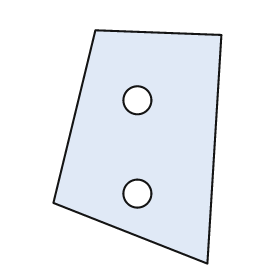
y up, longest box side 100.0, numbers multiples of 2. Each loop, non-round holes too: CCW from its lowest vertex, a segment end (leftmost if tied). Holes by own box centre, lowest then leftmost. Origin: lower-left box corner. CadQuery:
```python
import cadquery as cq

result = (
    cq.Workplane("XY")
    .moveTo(66.0, 0.0)
    .lineTo(72.0, 98.0)
    .lineTo(18.0, 100.0)
    .lineTo(0.0, 26.0)
    .close()
    .moveTo(36.0, 30.0)
    .circle(6.0)
    .moveTo(36.0, 70.0)
    .circle(6.0)
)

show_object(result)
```